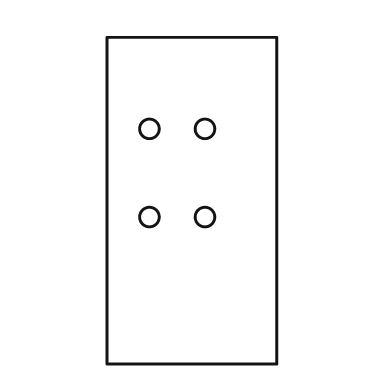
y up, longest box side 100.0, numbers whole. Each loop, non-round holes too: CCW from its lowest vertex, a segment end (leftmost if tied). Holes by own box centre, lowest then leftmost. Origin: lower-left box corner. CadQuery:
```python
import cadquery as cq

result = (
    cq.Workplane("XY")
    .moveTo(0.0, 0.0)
    .lineTo(52.0, 0.0)
    .lineTo(52.0, 100.0)
    .lineTo(0.0, 100.0)
    .close()
    .moveTo(13.0, 45.0)
    .circle(3.0)
    .moveTo(30.0, 45.0)
    .circle(3.0)
    .moveTo(13.0, 72.0)
    .circle(3.0)
    .moveTo(30.0, 72.0)
    .circle(3.0)
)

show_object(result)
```